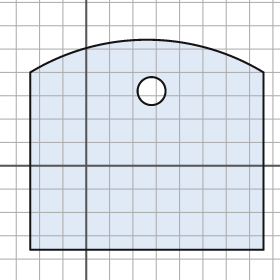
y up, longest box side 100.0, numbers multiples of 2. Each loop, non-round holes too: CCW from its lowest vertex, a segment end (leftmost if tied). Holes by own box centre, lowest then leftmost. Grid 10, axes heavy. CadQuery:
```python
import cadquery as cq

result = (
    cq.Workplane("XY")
    .moveTo(-24.0, -36.0)
    .lineTo(76.0, -36.0)
    .lineTo(76.0, 40.0)
    .threePointArc((26.0, 54.0), (-24.0, 40.0))
    .close()
    .moveTo(28.0, 32.0)
    .circle(6.0)
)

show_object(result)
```